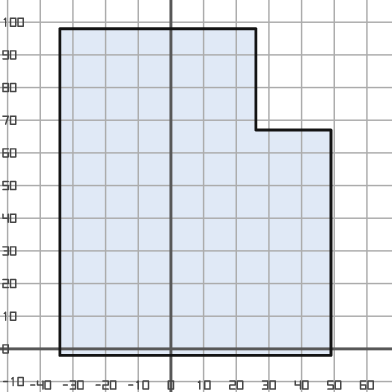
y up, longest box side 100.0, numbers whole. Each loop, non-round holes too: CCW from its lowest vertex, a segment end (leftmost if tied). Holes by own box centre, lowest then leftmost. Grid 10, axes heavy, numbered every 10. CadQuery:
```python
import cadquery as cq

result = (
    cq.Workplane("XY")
    .moveTo(-34.0, -2.0)
    .lineTo(49.0, -2.0)
    .lineTo(49.0, 67.0)
    .lineTo(26.0, 67.0)
    .lineTo(26.0, 98.0)
    .lineTo(-34.0, 98.0)
    .close()
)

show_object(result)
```